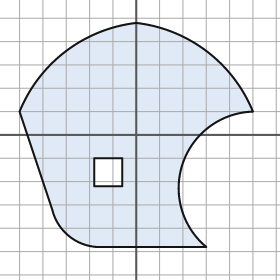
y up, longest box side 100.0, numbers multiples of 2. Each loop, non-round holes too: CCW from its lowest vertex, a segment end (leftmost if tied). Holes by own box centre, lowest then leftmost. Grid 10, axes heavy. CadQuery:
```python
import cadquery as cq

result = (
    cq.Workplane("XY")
    .moveTo(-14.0, -48.0)
    .lineTo(30.0, -48.0)
    .threePointArc((20.0, -12.0), (50.0, 10.0))
    .threePointArc((30.0, 36.0), (0.0, 48.0))
    .threePointArc((-30.0, 36.0), (-50.0, 10.0))
    .lineTo(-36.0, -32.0)
    .threePointArc((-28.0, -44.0), (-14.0, -48.0))
    .close()
    .moveTo(-18.0, -22.0)
    .lineTo(-6.0, -22.0)
    .lineTo(-6.0, -10.0)
    .lineTo(-18.0, -10.0)
    .close()
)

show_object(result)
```